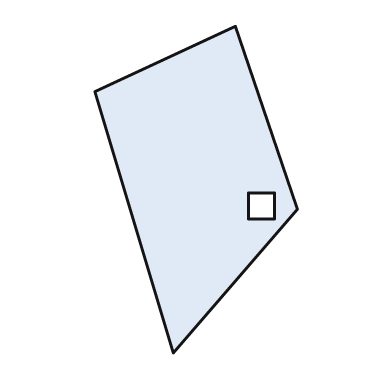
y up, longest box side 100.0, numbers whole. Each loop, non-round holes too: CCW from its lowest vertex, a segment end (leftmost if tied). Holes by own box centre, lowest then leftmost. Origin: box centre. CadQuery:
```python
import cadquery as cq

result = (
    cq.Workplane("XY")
    .moveTo(-7.0, -50.0)
    .lineTo(31.0, -6.0)
    .lineTo(12.0, 50.0)
    .lineTo(-31.0, 30.0)
    .close()
    .moveTo(16.0, -9.0)
    .lineTo(24.0, -9.0)
    .lineTo(24.0, -1.0)
    .lineTo(16.0, -1.0)
    .close()
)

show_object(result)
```